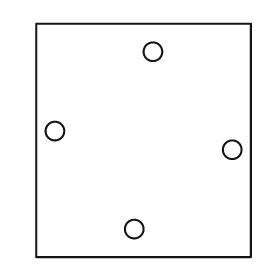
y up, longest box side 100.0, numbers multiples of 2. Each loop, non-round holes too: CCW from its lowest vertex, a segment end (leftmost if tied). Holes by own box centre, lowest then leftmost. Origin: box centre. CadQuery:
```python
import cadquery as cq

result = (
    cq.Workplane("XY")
    .moveTo(-46.0, -50.0)
    .lineTo(46.0, -50.0)
    .lineTo(46.0, 50.0)
    .lineTo(-46.0, 50.0)
    .close()
    .moveTo(-4.0, -38.0)
    .circle(4.0)
    .moveTo(38.0, -4.0)
    .circle(4.0)
    .moveTo(-38.0, 4.0)
    .circle(4.0)
    .moveTo(4.0, 38.0)
    .circle(4.0)
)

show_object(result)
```